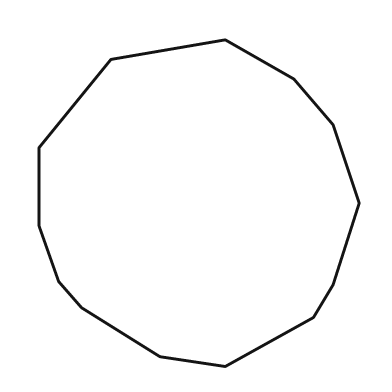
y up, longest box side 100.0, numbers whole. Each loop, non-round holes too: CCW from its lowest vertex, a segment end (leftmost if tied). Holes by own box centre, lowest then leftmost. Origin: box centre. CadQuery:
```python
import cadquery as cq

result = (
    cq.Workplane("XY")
    .moveTo(8.0, -50.0)
    .lineTo(35.0, -35.0)
    .lineTo(41.0, -25.0)
    .lineTo(49.0, 0.0)
    .lineTo(41.0, 24.0)
    .lineTo(29.0, 38.0)
    .lineTo(8.0, 50.0)
    .lineTo(-27.0, 44.0)
    .lineTo(-49.0, 17.0)
    .lineTo(-49.0, -7.0)
    .lineTo(-43.0, -24.0)
    .lineTo(-36.0, -32.0)
    .lineTo(-12.0, -47.0)
    .close()
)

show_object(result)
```